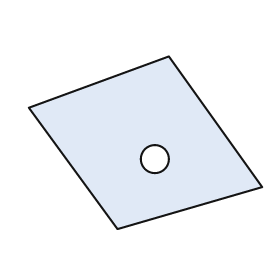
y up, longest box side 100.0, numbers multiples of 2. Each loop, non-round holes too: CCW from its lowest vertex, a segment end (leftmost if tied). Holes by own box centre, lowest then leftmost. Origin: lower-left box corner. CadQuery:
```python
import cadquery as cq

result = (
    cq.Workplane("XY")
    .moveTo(38.0, 0.0)
    .lineTo(100.0, 18.0)
    .lineTo(60.0, 74.0)
    .lineTo(0.0, 52.0)
    .close()
    .moveTo(54.0, 30.0)
    .circle(6.0)
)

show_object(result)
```